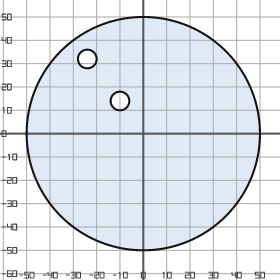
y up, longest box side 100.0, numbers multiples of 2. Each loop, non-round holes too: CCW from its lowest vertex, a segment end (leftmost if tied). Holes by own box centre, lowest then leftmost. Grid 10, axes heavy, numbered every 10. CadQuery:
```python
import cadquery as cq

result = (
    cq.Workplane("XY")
    .moveTo(0.0, 0.0)
    .circle(50.0)
    .moveTo(-10.0, 14.0)
    .circle(4.0)
    .moveTo(-24.0, 32.0)
    .circle(4.0)
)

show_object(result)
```